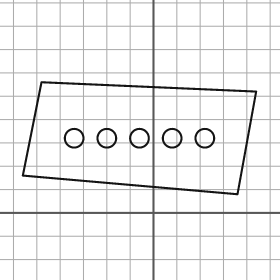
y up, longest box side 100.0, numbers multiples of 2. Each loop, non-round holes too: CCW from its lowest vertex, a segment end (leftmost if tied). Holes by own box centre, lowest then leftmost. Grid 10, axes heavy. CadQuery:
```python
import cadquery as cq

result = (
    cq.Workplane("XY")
    .moveTo(36.0, 8.0)
    .lineTo(44.0, 52.0)
    .lineTo(-48.0, 56.0)
    .lineTo(-56.0, 16.0)
    .close()
    .moveTo(-34.0, 32.0)
    .circle(4.0)
    .moveTo(-20.0, 32.0)
    .circle(4.0)
    .moveTo(-6.0, 32.0)
    .circle(4.0)
    .moveTo(8.0, 32.0)
    .circle(4.0)
    .moveTo(22.0, 32.0)
    .circle(4.0)
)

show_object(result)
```